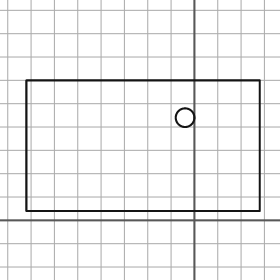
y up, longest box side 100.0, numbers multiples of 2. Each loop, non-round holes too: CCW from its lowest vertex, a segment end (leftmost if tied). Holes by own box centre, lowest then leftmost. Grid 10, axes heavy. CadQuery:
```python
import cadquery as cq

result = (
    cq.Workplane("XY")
    .moveTo(-72.0, 4.0)
    .lineTo(28.0, 4.0)
    .lineTo(28.0, 60.0)
    .lineTo(-72.0, 60.0)
    .close()
    .moveTo(-4.0, 44.0)
    .circle(4.0)
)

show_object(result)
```